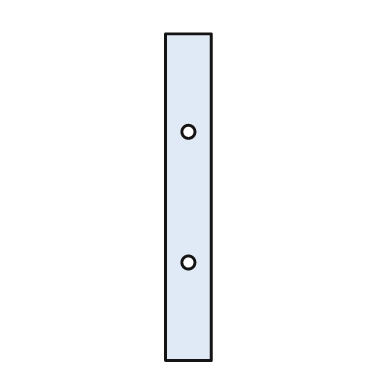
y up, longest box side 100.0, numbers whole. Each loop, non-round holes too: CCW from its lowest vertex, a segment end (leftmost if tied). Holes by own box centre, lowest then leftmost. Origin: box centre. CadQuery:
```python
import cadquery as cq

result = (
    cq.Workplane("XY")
    .moveTo(-7.0, -50.0)
    .lineTo(7.0, -50.0)
    .lineTo(7.0, 50.0)
    .lineTo(-7.0, 50.0)
    .close()
    .moveTo(0.0, -20.0)
    .circle(2.0)
    .moveTo(0.0, 20.0)
    .circle(2.0)
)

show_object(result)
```